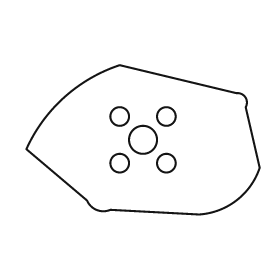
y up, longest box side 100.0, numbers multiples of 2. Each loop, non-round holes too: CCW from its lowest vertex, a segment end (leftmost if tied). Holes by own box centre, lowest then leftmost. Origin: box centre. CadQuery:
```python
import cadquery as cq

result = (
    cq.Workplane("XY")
    .moveTo(24.0, -32.0)
    .threePointArc((40.0, -26.0), (50.0, -12.0))
    .lineTo(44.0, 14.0)
    .threePointArc((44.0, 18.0), (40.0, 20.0))
    .lineTo(-10.0, 32.0)
    .threePointArc((-34.0, 18.0), (-50.0, -4.0))
    .lineTo(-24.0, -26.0)
    .threePointArc((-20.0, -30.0), (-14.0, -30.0))
    .close()
    .moveTo(-10.0, -10.0)
    .circle(4.0)
    .moveTo(10.0, -10.0)
    .circle(4.0)
    .moveTo(0.0, 0.0)
    .circle(6.0)
    .moveTo(-10.0, 10.0)
    .circle(4.0)
    .moveTo(10.0, 10.0)
    .circle(4.0)
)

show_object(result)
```